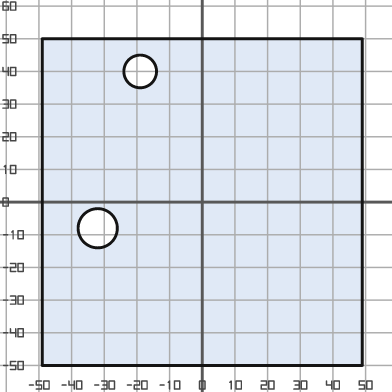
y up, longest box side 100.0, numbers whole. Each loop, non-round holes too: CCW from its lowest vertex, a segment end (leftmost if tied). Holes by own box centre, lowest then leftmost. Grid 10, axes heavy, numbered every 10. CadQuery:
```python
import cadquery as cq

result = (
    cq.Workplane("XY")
    .moveTo(-49.0, -50.0)
    .lineTo(49.0, -50.0)
    .lineTo(49.0, 50.0)
    .lineTo(-49.0, 50.0)
    .close()
    .moveTo(-32.0, -8.0)
    .circle(6.0)
    .moveTo(-19.0, 40.0)
    .circle(5.0)
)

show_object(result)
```